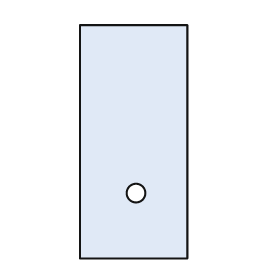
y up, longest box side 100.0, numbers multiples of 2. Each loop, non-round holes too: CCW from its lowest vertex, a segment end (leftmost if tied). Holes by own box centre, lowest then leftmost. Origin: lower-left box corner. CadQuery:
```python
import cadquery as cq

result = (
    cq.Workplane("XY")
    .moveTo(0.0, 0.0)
    .lineTo(46.0, 0.0)
    .lineTo(46.0, 100.0)
    .lineTo(0.0, 100.0)
    .close()
    .moveTo(24.0, 28.0)
    .circle(4.0)
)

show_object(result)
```